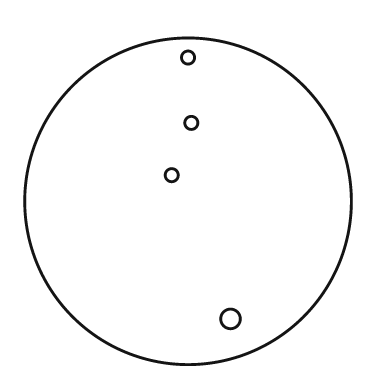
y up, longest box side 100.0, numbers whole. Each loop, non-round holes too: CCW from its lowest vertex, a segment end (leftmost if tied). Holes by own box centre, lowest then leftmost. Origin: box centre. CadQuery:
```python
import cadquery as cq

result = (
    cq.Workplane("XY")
    .moveTo(0.0, 0.0)
    .circle(50.0)
    .moveTo(13.0, -36.0)
    .circle(3.0)
    .moveTo(-5.0, 8.0)
    .circle(2.0)
    .moveTo(1.0, 24.0)
    .circle(2.0)
    .moveTo(0.0, 44.0)
    .circle(2.0)
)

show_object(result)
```